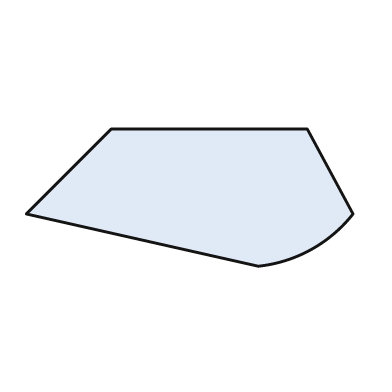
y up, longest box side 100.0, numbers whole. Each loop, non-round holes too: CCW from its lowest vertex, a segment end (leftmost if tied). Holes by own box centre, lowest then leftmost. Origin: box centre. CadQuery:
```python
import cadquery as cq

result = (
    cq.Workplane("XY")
    .moveTo(21.0, -21.0)
    .threePointArc((37.0, -16.0), (50.0, -5.0))
    .lineTo(36.0, 21.0)
    .lineTo(-24.0, 21.0)
    .lineTo(-50.0, -5.0)
    .close()
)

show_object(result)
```